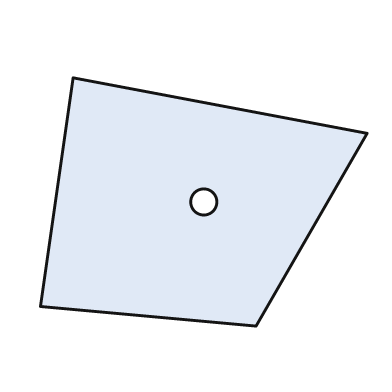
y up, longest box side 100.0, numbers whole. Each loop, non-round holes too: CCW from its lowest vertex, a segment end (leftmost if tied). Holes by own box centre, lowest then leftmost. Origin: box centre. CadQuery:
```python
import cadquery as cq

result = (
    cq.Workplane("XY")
    .moveTo(16.0, -38.0)
    .lineTo(50.0, 21.0)
    .lineTo(-40.0, 38.0)
    .lineTo(-50.0, -32.0)
    .close()
    .moveTo(0.0, 0.0)
    .circle(4.0)
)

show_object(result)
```